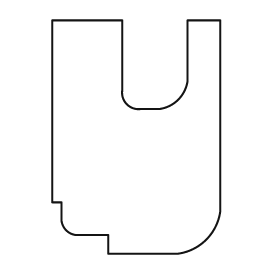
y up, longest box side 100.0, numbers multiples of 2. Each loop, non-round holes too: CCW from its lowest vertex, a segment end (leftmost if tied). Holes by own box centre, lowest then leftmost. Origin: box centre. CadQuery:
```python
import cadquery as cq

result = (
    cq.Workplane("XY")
    .moveTo(-12.0, -50.0)
    .lineTo(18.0, -50.0)
    .threePointArc((30.0, -44.0), (36.0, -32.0))
    .lineTo(36.0, 50.0)
    .lineTo(22.0, 50.0)
    .lineTo(22.0, 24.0)
    .threePointArc((18.0, 16.0), (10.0, 12.0))
    .lineTo(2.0, 12.0)
    .threePointArc((-4.0, 14.0), (-6.0, 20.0))
    .lineTo(-6.0, 50.0)
    .lineTo(-36.0, 50.0)
    .lineTo(-36.0, -28.0)
    .lineTo(-32.0, -28.0)
    .lineTo(-32.0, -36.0)
    .threePointArc((-30.0, -40.0), (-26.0, -42.0))
    .lineTo(-12.0, -42.0)
    .close()
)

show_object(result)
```